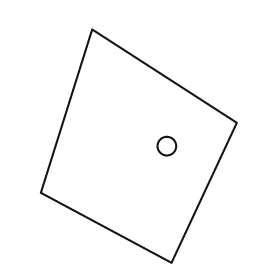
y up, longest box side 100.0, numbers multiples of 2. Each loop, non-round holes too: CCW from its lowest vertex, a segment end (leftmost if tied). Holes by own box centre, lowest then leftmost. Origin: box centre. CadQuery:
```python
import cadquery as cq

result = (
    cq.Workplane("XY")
    .moveTo(14.0, -50.0)
    .lineTo(42.0, 10.0)
    .lineTo(-20.0, 50.0)
    .lineTo(-42.0, -20.0)
    .close()
    .moveTo(12.0, 0.0)
    .circle(4.0)
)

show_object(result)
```